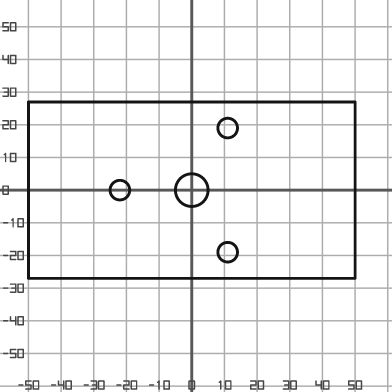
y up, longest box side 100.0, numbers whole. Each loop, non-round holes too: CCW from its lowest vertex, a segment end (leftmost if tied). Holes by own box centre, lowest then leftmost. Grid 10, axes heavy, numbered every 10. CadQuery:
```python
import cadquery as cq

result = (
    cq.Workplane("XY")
    .moveTo(-50.0, -27.0)
    .lineTo(50.0, -27.0)
    .lineTo(50.0, 27.0)
    .lineTo(-50.0, 27.0)
    .close()
    .moveTo(11.0, -19.0)
    .circle(3.0)
    .moveTo(-22.0, 0.0)
    .circle(3.0)
    .moveTo(0.0, 0.0)
    .circle(5.0)
    .moveTo(11.0, 19.0)
    .circle(3.0)
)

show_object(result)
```